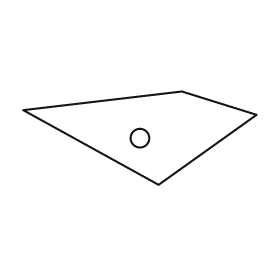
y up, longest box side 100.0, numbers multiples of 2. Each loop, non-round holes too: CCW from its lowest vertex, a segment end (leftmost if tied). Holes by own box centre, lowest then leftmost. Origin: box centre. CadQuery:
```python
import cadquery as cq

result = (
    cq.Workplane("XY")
    .moveTo(8.0, -20.0)
    .lineTo(50.0, 10.0)
    .lineTo(18.0, 20.0)
    .lineTo(-50.0, 12.0)
    .close()
    .moveTo(0.0, 0.0)
    .circle(4.0)
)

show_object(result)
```